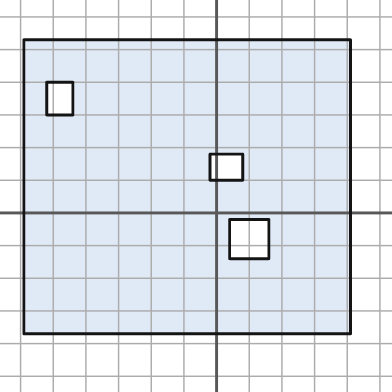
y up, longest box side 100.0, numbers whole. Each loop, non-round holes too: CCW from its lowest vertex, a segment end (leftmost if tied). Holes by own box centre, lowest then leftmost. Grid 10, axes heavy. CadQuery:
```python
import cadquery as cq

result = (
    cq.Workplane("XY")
    .moveTo(-59.0, -37.0)
    .lineTo(41.0, -37.0)
    .lineTo(41.0, 53.0)
    .lineTo(-59.0, 53.0)
    .close()
    .moveTo(4.0, -14.0)
    .lineTo(16.0, -14.0)
    .lineTo(16.0, -2.0)
    .lineTo(4.0, -2.0)
    .close()
    .moveTo(-2.0, 10.0)
    .lineTo(8.0, 10.0)
    .lineTo(8.0, 18.0)
    .lineTo(-2.0, 18.0)
    .close()
    .moveTo(-52.0, 30.0)
    .lineTo(-44.0, 30.0)
    .lineTo(-44.0, 40.0)
    .lineTo(-52.0, 40.0)
    .close()
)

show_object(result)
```